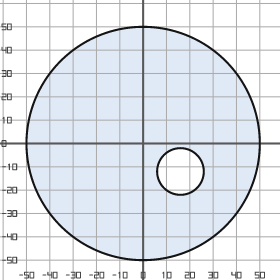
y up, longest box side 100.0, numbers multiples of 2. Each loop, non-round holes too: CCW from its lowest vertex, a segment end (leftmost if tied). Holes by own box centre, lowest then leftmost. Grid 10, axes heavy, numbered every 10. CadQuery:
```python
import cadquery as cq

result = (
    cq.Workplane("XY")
    .moveTo(0.0, 0.0)
    .circle(50.0)
    .moveTo(16.0, -12.0)
    .circle(10.0)
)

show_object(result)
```